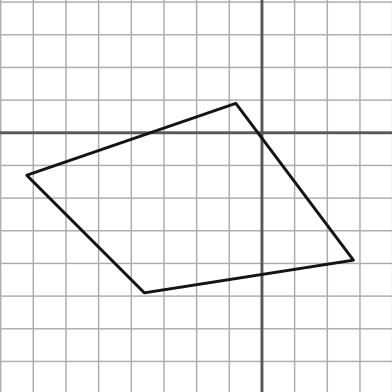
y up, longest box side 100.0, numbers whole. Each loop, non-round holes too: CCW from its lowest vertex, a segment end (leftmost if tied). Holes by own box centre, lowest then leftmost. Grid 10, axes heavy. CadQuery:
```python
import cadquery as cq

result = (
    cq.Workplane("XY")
    .moveTo(-36.0, -49.0)
    .lineTo(28.0, -39.0)
    .lineTo(-8.0, 9.0)
    .lineTo(-72.0, -13.0)
    .close()
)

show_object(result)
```